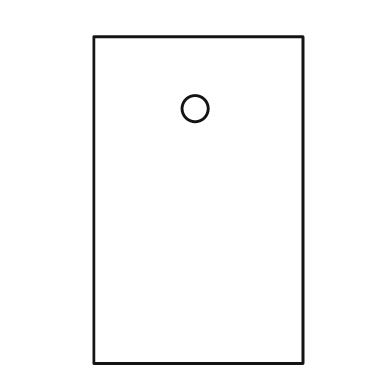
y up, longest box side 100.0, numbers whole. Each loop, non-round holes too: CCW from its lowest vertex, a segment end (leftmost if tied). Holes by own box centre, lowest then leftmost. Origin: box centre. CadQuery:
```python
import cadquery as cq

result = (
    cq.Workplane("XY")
    .moveTo(-32.0, -50.0)
    .lineTo(32.0, -50.0)
    .lineTo(32.0, 50.0)
    .lineTo(-32.0, 50.0)
    .close()
    .moveTo(-1.0, 28.0)
    .circle(4.0)
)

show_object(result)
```